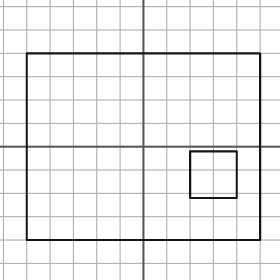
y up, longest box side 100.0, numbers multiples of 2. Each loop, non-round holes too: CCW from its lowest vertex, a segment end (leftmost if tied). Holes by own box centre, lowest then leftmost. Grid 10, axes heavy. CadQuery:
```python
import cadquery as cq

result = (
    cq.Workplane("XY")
    .moveTo(-50.0, -40.0)
    .lineTo(50.0, -40.0)
    .lineTo(50.0, 40.0)
    .lineTo(-50.0, 40.0)
    .close()
    .moveTo(20.0, -22.0)
    .lineTo(40.0, -22.0)
    .lineTo(40.0, -2.0)
    .lineTo(20.0, -2.0)
    .close()
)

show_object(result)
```